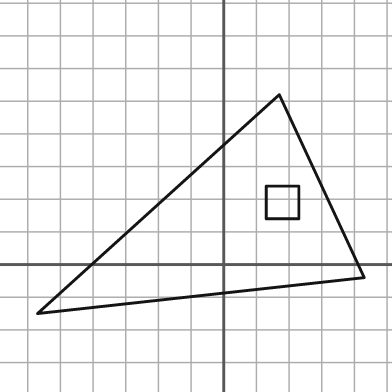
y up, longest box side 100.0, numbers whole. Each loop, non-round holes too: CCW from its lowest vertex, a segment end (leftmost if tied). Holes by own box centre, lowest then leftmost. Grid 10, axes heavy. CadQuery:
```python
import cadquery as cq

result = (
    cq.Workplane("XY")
    .moveTo(-57.0, -15.0)
    .lineTo(43.0, -4.0)
    .lineTo(17.0, 52.0)
    .close()
    .moveTo(13.0, 14.0)
    .lineTo(23.0, 14.0)
    .lineTo(23.0, 24.0)
    .lineTo(13.0, 24.0)
    .close()
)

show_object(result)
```